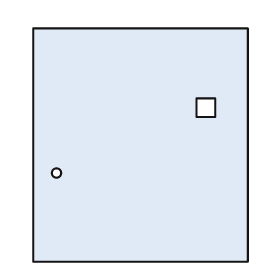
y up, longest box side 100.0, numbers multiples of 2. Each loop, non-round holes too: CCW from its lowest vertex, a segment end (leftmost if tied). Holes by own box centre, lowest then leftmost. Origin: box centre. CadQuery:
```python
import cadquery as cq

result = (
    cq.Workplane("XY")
    .moveTo(-46.0, -50.0)
    .lineTo(46.0, -50.0)
    .lineTo(46.0, 50.0)
    .lineTo(-46.0, 50.0)
    .close()
    .moveTo(-36.0, -12.0)
    .circle(2.0)
    .moveTo(24.0, 12.0)
    .lineTo(32.0, 12.0)
    .lineTo(32.0, 20.0)
    .lineTo(24.0, 20.0)
    .close()
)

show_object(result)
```